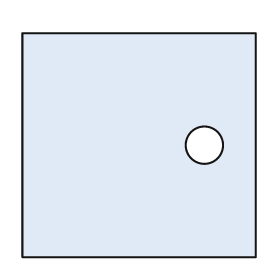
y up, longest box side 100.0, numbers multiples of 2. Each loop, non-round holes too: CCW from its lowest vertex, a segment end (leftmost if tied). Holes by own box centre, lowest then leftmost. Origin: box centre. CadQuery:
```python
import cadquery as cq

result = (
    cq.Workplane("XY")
    .moveTo(-50.0, -48.0)
    .lineTo(50.0, -48.0)
    .lineTo(50.0, 48.0)
    .lineTo(-50.0, 48.0)
    .close()
    .moveTo(28.0, 0.0)
    .circle(8.0)
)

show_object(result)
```